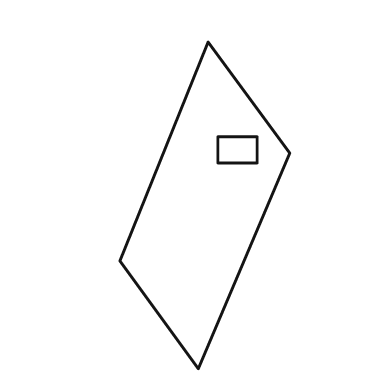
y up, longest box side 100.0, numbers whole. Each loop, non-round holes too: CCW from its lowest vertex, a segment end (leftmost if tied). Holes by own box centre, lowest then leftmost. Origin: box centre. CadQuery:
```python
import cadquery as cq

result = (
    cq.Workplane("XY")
    .moveTo(-2.0, -50.0)
    .lineTo(26.0, 16.0)
    .lineTo(1.0, 50.0)
    .lineTo(-26.0, -17.0)
    .close()
    .moveTo(4.0, 13.0)
    .lineTo(16.0, 13.0)
    .lineTo(16.0, 21.0)
    .lineTo(4.0, 21.0)
    .close()
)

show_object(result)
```